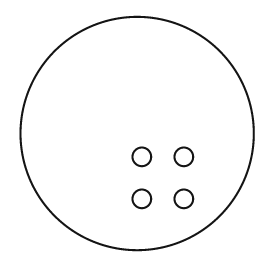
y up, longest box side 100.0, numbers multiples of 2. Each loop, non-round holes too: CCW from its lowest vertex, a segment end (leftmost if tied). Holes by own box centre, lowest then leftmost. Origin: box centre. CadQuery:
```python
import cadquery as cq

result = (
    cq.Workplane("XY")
    .moveTo(0.0, 0.0)
    .circle(50.0)
    .moveTo(2.0, -28.0)
    .circle(4.0)
    .moveTo(20.0, -28.0)
    .circle(4.0)
    .moveTo(2.0, -10.0)
    .circle(4.0)
    .moveTo(20.0, -10.0)
    .circle(4.0)
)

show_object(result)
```